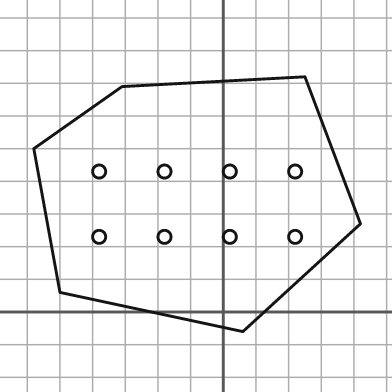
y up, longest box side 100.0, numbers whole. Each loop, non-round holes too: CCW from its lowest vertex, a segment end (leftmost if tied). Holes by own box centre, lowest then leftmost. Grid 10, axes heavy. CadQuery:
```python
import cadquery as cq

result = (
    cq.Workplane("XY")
    .moveTo(6.0, -6.0)
    .lineTo(42.0, 27.0)
    .lineTo(25.0, 72.0)
    .lineTo(-31.0, 69.0)
    .lineTo(-58.0, 50.0)
    .lineTo(-50.0, 6.0)
    .close()
    .moveTo(-38.0, 23.0)
    .circle(2.0)
    .moveTo(-18.0, 23.0)
    .circle(2.0)
    .moveTo(2.0, 23.0)
    .circle(2.0)
    .moveTo(22.0, 23.0)
    .circle(2.0)
    .moveTo(-38.0, 43.0)
    .circle(2.0)
    .moveTo(-18.0, 43.0)
    .circle(2.0)
    .moveTo(2.0, 43.0)
    .circle(2.0)
    .moveTo(22.0, 43.0)
    .circle(2.0)
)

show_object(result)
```